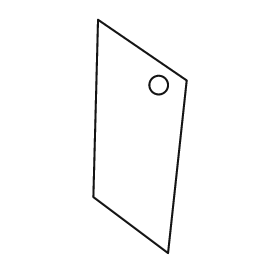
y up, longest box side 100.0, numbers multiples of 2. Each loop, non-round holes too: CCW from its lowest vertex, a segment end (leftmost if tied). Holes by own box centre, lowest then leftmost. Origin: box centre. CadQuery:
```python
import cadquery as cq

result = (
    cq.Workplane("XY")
    .moveTo(12.0, -50.0)
    .lineTo(20.0, 24.0)
    .lineTo(-18.0, 50.0)
    .lineTo(-20.0, -26.0)
    .close()
    .moveTo(8.0, 22.0)
    .circle(4.0)
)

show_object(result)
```